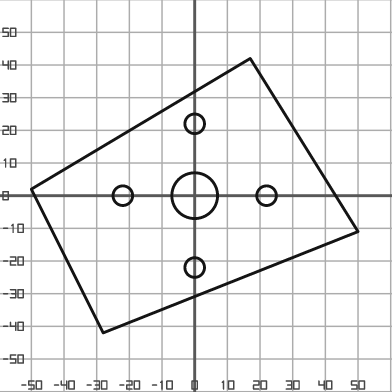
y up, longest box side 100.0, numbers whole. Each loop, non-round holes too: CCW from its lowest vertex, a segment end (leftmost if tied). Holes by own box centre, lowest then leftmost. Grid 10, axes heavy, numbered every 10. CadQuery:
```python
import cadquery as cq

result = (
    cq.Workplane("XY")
    .moveTo(-28.0, -42.0)
    .lineTo(50.0, -11.0)
    .lineTo(17.0, 42.0)
    .lineTo(-50.0, 2.0)
    .close()
    .moveTo(0.0, -22.0)
    .circle(3.0)
    .moveTo(-22.0, 0.0)
    .circle(3.0)
    .moveTo(0.0, 0.0)
    .circle(7.0)
    .moveTo(22.0, 0.0)
    .circle(3.0)
    .moveTo(0.0, 22.0)
    .circle(3.0)
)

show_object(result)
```